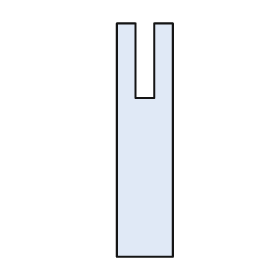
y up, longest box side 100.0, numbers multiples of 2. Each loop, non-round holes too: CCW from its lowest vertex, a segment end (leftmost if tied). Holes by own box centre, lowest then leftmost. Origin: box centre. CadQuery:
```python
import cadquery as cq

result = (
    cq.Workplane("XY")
    .moveTo(-12.0, -50.0)
    .lineTo(12.0, -50.0)
    .lineTo(12.0, 50.0)
    .lineTo(4.0, 50.0)
    .lineTo(4.0, 18.0)
    .lineTo(-4.0, 18.0)
    .lineTo(-4.0, 50.0)
    .lineTo(-12.0, 50.0)
    .close()
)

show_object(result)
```